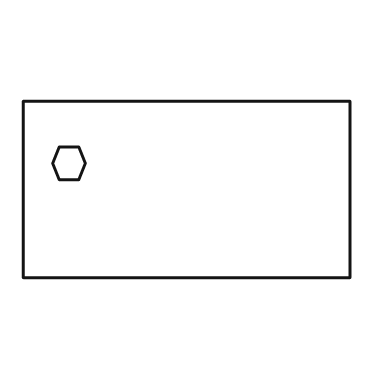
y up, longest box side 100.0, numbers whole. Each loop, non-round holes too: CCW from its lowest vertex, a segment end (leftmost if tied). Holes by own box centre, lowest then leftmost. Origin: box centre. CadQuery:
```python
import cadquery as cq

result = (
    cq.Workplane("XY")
    .moveTo(-50.0, -27.0)
    .lineTo(50.0, -27.0)
    .lineTo(50.0, 27.0)
    .lineTo(-50.0, 27.0)
    .close()
    .moveTo(-39.0, 3.0)
    .lineTo(-33.0, 3.0)
    .lineTo(-31.0, 8.0)
    .lineTo(-33.0, 13.0)
    .lineTo(-39.0, 13.0)
    .lineTo(-41.0, 8.0)
    .close()
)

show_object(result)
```